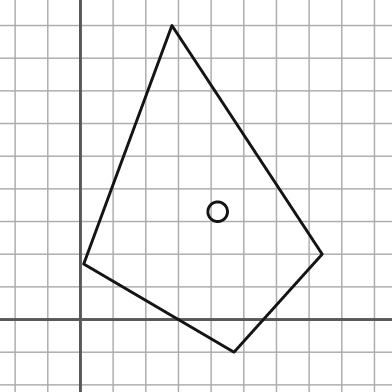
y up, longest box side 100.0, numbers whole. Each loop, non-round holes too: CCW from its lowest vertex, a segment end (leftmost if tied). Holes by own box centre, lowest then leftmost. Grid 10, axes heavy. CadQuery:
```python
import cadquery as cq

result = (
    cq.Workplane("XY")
    .moveTo(47.0, -10.0)
    .lineTo(74.0, 20.0)
    .lineTo(28.0, 90.0)
    .lineTo(1.0, 17.0)
    .close()
    .moveTo(42.0, 33.0)
    .circle(3.0)
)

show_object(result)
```